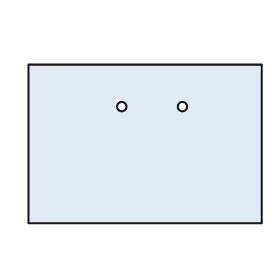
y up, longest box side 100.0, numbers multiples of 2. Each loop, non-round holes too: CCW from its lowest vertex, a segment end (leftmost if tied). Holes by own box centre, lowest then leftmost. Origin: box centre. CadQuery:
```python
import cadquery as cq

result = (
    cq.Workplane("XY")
    .moveTo(-50.0, -34.0)
    .lineTo(50.0, -34.0)
    .lineTo(50.0, 34.0)
    .lineTo(-50.0, 34.0)
    .close()
    .moveTo(-10.0, 16.0)
    .circle(2.0)
    .moveTo(16.0, 16.0)
    .circle(2.0)
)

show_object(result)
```